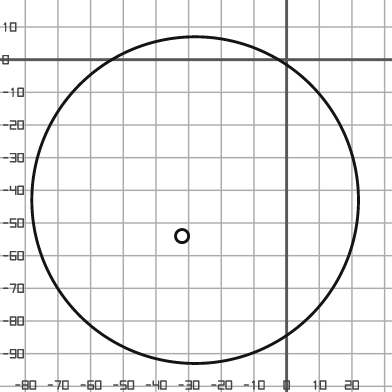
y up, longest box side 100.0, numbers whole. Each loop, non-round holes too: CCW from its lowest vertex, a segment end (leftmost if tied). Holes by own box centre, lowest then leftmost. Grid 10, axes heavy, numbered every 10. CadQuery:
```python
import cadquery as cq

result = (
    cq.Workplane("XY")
    .moveTo(-28.0, -43.0)
    .circle(50.0)
    .moveTo(-32.0, -54.0)
    .circle(2.0)
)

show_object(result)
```